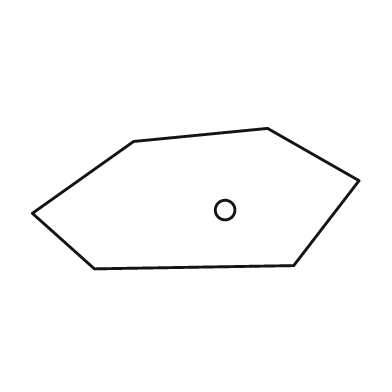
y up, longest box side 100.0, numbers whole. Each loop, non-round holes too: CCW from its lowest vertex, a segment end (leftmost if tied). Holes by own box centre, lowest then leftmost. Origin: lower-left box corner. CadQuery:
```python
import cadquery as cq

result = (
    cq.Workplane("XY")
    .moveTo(19.0, 0.0)
    .lineTo(80.0, 1.0)
    .lineTo(100.0, 27.0)
    .lineTo(72.0, 43.0)
    .lineTo(31.0, 39.0)
    .lineTo(0.0, 17.0)
    .close()
    .moveTo(59.0, 18.0)
    .circle(3.0)
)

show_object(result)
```